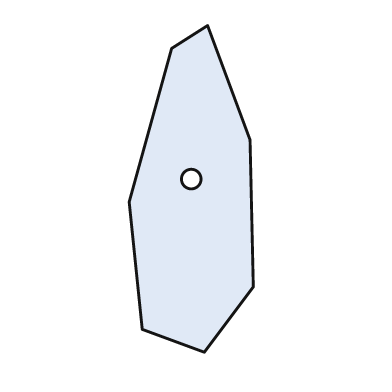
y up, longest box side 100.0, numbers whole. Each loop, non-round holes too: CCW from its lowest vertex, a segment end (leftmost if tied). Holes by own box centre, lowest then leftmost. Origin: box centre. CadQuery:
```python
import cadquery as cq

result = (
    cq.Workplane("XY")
    .moveTo(4.0, -50.0)
    .lineTo(19.0, -30.0)
    .lineTo(18.0, 15.0)
    .lineTo(5.0, 50.0)
    .lineTo(-6.0, 43.0)
    .lineTo(-19.0, -4.0)
    .lineTo(-15.0, -43.0)
    .close()
    .moveTo(0.0, 3.0)
    .circle(3.0)
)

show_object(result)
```